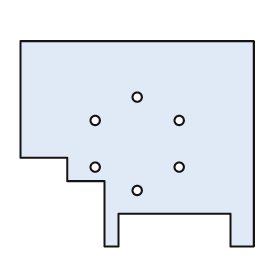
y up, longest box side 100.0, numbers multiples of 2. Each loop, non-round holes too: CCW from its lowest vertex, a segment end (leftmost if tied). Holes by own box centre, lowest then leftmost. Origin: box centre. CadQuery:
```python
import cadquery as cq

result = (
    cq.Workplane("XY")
    .moveTo(-14.0, -44.0)
    .lineTo(-8.0, -44.0)
    .lineTo(-8.0, -30.0)
    .lineTo(40.0, -30.0)
    .lineTo(40.0, -44.0)
    .lineTo(50.0, -44.0)
    .lineTo(50.0, 44.0)
    .lineTo(-50.0, 44.0)
    .lineTo(-50.0, -6.0)
    .lineTo(-30.0, -6.0)
    .lineTo(-30.0, -16.0)
    .lineTo(-14.0, -16.0)
    .close()
    .moveTo(0.0, -20.0)
    .circle(2.0)
    .moveTo(-18.0, -10.0)
    .circle(2.0)
    .moveTo(18.0, -10.0)
    .circle(2.0)
    .moveTo(-18.0, 10.0)
    .circle(2.0)
    .moveTo(18.0, 10.0)
    .circle(2.0)
    .moveTo(0.0, 20.0)
    .circle(2.0)
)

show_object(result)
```